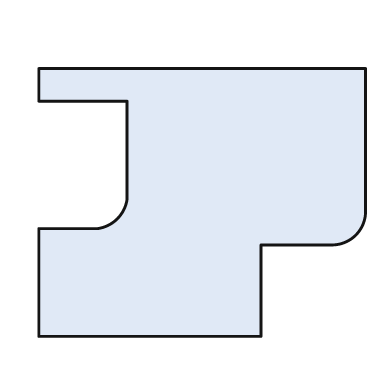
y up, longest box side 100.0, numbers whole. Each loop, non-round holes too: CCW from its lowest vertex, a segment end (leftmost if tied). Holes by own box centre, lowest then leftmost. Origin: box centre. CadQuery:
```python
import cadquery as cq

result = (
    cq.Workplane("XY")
    .moveTo(-50.0, -41.0)
    .lineTo(18.0, -41.0)
    .lineTo(18.0, -13.0)
    .lineTo(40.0, -13.0)
    .threePointArc((47.0, -10.0), (50.0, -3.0))
    .lineTo(50.0, 41.0)
    .lineTo(-50.0, 41.0)
    .lineTo(-50.0, 31.0)
    .lineTo(-23.0, 31.0)
    .lineTo(-23.0, 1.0)
    .threePointArc((-26.0, -5.0), (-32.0, -8.0))
    .lineTo(-50.0, -8.0)
    .close()
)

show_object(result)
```